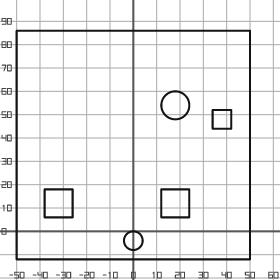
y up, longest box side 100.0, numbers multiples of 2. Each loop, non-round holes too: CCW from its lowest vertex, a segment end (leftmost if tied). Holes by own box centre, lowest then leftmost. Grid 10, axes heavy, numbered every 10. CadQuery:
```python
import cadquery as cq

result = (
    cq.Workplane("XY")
    .moveTo(-50.0, -12.0)
    .lineTo(50.0, -12.0)
    .lineTo(50.0, 86.0)
    .lineTo(-50.0, 86.0)
    .close()
    .moveTo(0.0, -4.0)
    .circle(4.0)
    .moveTo(-38.0, 6.0)
    .lineTo(-26.0, 6.0)
    .lineTo(-26.0, 18.0)
    .lineTo(-38.0, 18.0)
    .close()
    .moveTo(12.0, 6.0)
    .lineTo(24.0, 6.0)
    .lineTo(24.0, 18.0)
    .lineTo(12.0, 18.0)
    .close()
    .moveTo(34.0, 44.0)
    .lineTo(42.0, 44.0)
    .lineTo(42.0, 52.0)
    .lineTo(34.0, 52.0)
    .close()
    .moveTo(18.0, 54.0)
    .circle(6.0)
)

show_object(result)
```